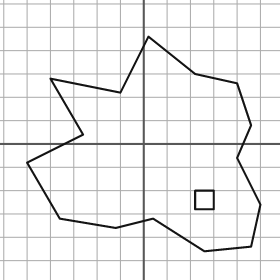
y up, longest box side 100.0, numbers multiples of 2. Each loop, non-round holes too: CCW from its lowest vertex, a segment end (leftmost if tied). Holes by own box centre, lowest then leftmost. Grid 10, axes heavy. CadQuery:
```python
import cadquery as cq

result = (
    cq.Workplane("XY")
    .moveTo(26.0, -46.0)
    .lineTo(46.0, -44.0)
    .lineTo(50.0, -26.0)
    .lineTo(40.0, -6.0)
    .lineTo(46.0, 8.0)
    .lineTo(40.0, 26.0)
    .lineTo(22.0, 30.0)
    .lineTo(2.0, 46.0)
    .lineTo(-10.0, 22.0)
    .lineTo(-40.0, 28.0)
    .lineTo(-26.0, 4.0)
    .lineTo(-50.0, -8.0)
    .lineTo(-36.0, -32.0)
    .lineTo(-12.0, -36.0)
    .lineTo(4.0, -32.0)
    .close()
    .moveTo(22.0, -28.0)
    .lineTo(30.0, -28.0)
    .lineTo(30.0, -20.0)
    .lineTo(22.0, -20.0)
    .close()
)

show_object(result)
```